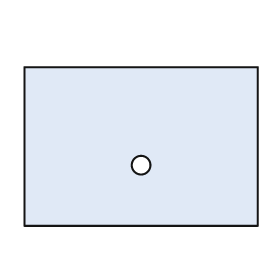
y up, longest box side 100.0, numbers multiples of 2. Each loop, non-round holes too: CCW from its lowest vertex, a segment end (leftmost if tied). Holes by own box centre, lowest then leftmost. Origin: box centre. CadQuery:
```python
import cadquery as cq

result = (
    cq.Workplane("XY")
    .moveTo(-50.0, -34.0)
    .lineTo(50.0, -34.0)
    .lineTo(50.0, 34.0)
    .lineTo(-50.0, 34.0)
    .close()
    .moveTo(0.0, -8.0)
    .circle(4.0)
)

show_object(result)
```